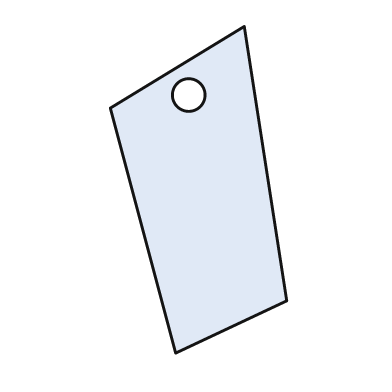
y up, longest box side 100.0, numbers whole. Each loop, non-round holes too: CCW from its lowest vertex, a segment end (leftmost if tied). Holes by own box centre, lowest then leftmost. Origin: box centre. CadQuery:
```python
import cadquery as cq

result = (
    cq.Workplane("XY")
    .moveTo(-7.0, -50.0)
    .lineTo(27.0, -34.0)
    .lineTo(14.0, 50.0)
    .lineTo(-27.0, 25.0)
    .close()
    .moveTo(-3.0, 29.0)
    .circle(5.0)
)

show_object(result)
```